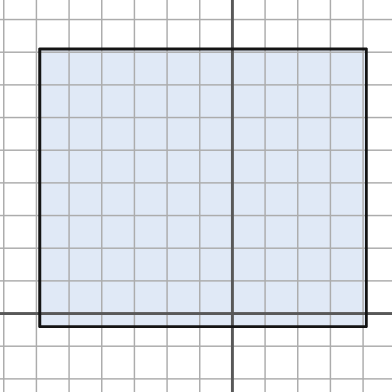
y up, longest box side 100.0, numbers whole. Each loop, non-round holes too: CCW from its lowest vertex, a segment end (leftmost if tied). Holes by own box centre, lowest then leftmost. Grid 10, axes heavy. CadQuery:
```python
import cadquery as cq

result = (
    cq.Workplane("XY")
    .moveTo(-59.0, -4.0)
    .lineTo(41.0, -4.0)
    .lineTo(41.0, 81.0)
    .lineTo(-59.0, 81.0)
    .close()
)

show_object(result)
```